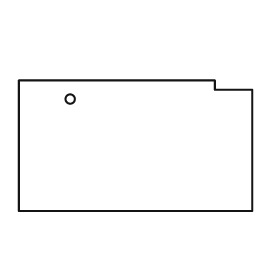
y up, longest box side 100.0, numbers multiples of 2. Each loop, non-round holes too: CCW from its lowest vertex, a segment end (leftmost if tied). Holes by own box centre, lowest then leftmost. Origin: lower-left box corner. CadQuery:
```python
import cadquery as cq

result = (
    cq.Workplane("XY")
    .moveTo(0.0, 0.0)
    .lineTo(100.0, 0.0)
    .lineTo(100.0, 52.0)
    .lineTo(84.0, 52.0)
    .lineTo(84.0, 56.0)
    .lineTo(0.0, 56.0)
    .close()
    .moveTo(22.0, 48.0)
    .circle(2.0)
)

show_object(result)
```